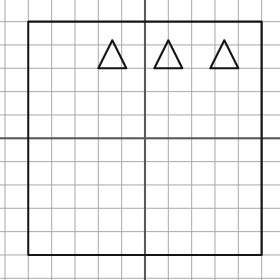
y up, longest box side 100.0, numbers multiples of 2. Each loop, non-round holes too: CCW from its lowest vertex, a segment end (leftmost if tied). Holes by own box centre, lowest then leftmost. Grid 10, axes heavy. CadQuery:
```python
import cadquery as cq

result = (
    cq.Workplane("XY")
    .moveTo(-50.0, -50.0)
    .lineTo(50.0, -50.0)
    .lineTo(50.0, 50.0)
    .lineTo(-50.0, 50.0)
    .close()
    .moveTo(-20.0, 30.0)
    .lineTo(-8.0, 30.0)
    .lineTo(-14.0, 42.0)
    .close()
    .moveTo(4.0, 30.0)
    .lineTo(16.0, 30.0)
    .lineTo(10.0, 42.0)
    .close()
    .moveTo(28.0, 30.0)
    .lineTo(40.0, 30.0)
    .lineTo(34.0, 42.0)
    .close()
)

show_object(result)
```